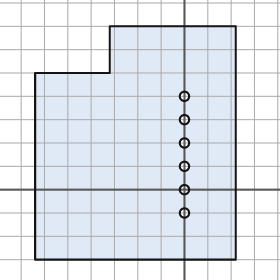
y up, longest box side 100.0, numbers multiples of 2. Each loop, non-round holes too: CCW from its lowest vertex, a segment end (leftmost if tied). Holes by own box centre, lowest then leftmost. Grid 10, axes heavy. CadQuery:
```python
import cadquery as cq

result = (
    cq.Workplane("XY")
    .moveTo(-64.0, -30.0)
    .lineTo(22.0, -30.0)
    .lineTo(22.0, 70.0)
    .lineTo(-32.0, 70.0)
    .lineTo(-32.0, 50.0)
    .lineTo(-64.0, 50.0)
    .close()
    .moveTo(0.0, -10.0)
    .circle(2.0)
    .moveTo(0.0, 0.0)
    .circle(2.0)
    .moveTo(0.0, 10.0)
    .circle(2.0)
    .moveTo(0.0, 20.0)
    .circle(2.0)
    .moveTo(0.0, 30.0)
    .circle(2.0)
    .moveTo(0.0, 40.0)
    .circle(2.0)
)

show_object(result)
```